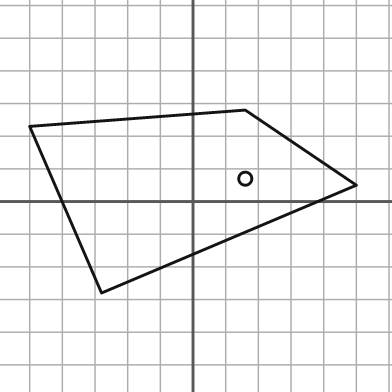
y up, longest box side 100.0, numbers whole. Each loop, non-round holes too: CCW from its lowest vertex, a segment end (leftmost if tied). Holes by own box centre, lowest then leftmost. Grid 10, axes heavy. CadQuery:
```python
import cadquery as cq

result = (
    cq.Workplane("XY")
    .moveTo(-28.0, -28.0)
    .lineTo(50.0, 5.0)
    .lineTo(16.0, 28.0)
    .lineTo(-50.0, 23.0)
    .close()
    .moveTo(16.0, 7.0)
    .circle(2.0)
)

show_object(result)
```